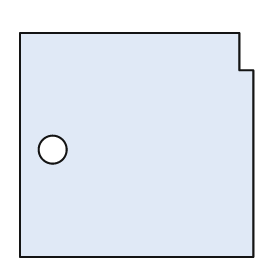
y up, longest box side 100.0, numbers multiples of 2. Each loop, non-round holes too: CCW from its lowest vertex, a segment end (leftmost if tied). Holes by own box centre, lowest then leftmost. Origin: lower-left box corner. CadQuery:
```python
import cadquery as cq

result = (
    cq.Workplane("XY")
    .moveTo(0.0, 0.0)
    .lineTo(100.0, 0.0)
    .lineTo(100.0, 80.0)
    .lineTo(94.0, 80.0)
    .lineTo(94.0, 96.0)
    .lineTo(0.0, 96.0)
    .close()
    .moveTo(14.0, 46.0)
    .circle(6.0)
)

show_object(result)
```